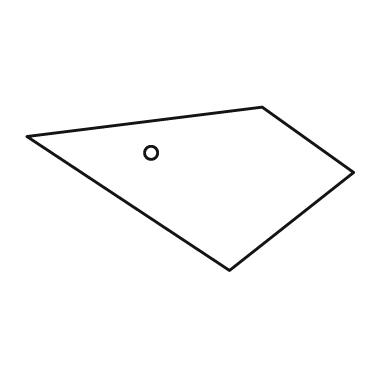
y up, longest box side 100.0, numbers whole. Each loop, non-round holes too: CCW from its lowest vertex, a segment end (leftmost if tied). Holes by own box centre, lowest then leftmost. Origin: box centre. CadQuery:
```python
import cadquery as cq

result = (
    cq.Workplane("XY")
    .moveTo(12.0, -25.0)
    .lineTo(50.0, 5.0)
    .lineTo(22.0, 25.0)
    .lineTo(-50.0, 16.0)
    .close()
    .moveTo(-12.0, 11.0)
    .circle(2.0)
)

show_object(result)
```